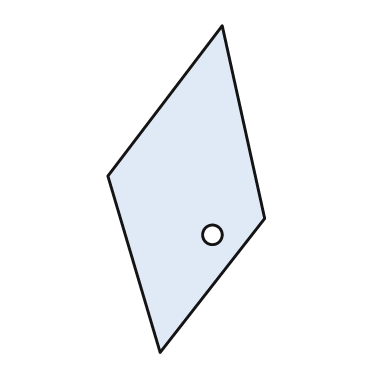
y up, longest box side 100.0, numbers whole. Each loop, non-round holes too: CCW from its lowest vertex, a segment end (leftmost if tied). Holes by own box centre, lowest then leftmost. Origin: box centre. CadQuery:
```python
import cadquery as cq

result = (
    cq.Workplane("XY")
    .moveTo(-8.0, -50.0)
    .lineTo(24.0, -9.0)
    .lineTo(11.0, 50.0)
    .lineTo(-24.0, 4.0)
    .close()
    .moveTo(8.0, -14.0)
    .circle(3.0)
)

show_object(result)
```